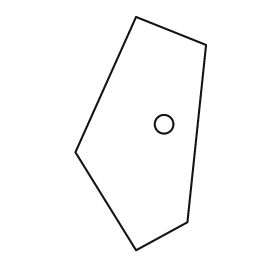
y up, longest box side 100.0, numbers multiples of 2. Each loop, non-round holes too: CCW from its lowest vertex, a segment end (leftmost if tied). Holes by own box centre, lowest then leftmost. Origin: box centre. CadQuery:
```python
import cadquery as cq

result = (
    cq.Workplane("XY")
    .moveTo(-2.0, -50.0)
    .lineTo(20.0, -38.0)
    .lineTo(28.0, 38.0)
    .lineTo(-2.0, 50.0)
    .lineTo(-28.0, -8.0)
    .close()
    .moveTo(10.0, 4.0)
    .circle(4.0)
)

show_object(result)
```